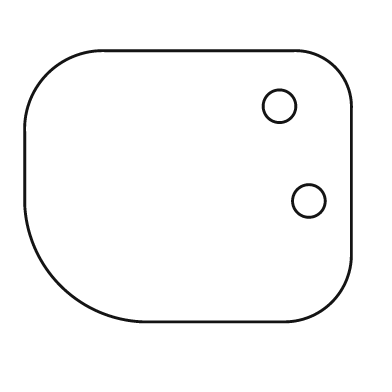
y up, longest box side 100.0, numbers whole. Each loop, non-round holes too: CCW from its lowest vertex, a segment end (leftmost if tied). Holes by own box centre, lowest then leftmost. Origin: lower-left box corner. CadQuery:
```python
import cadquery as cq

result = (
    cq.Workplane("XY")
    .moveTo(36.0, 0.0)
    .lineTo(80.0, 0.0)
    .threePointArc((94.0, 6.0), (100.0, 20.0))
    .lineTo(100.0, 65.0)
    .threePointArc((95.0, 78.0), (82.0, 83.0))
    .lineTo(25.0, 83.0)
    .threePointArc((7.0, 76.0), (0.0, 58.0))
    .lineTo(0.0, 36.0)
    .threePointArc((11.0, 11.0), (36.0, 0.0))
    .close()
    .moveTo(87.0, 37.0)
    .circle(5.0)
    .moveTo(78.0, 66.0)
    .circle(5.0)
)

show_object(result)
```